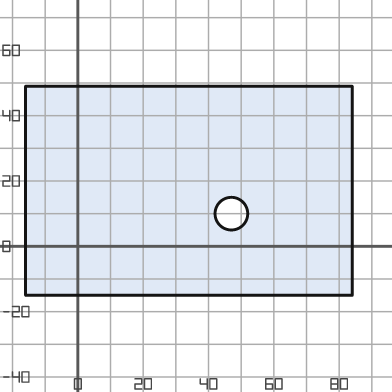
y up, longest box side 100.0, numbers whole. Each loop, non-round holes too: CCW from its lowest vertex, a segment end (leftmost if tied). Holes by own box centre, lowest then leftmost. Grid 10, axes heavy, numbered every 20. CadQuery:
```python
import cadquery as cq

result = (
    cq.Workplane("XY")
    .moveTo(-16.0, -15.0)
    .lineTo(84.0, -15.0)
    .lineTo(84.0, 49.0)
    .lineTo(-16.0, 49.0)
    .close()
    .moveTo(47.0, 10.0)
    .circle(5.0)
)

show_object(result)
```